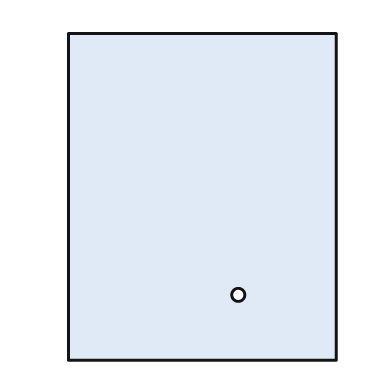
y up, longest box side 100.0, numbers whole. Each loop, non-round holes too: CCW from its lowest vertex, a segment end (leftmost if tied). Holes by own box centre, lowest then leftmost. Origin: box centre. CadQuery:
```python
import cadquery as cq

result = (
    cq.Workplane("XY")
    .moveTo(-41.0, -50.0)
    .lineTo(41.0, -50.0)
    .lineTo(41.0, 50.0)
    .lineTo(-41.0, 50.0)
    .close()
    .moveTo(11.0, -30.0)
    .circle(2.0)
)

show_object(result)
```